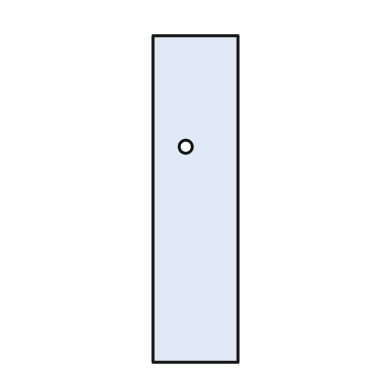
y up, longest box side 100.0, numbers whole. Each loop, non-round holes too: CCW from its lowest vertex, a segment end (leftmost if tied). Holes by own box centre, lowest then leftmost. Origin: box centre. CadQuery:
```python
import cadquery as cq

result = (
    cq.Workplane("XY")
    .moveTo(-13.0, -50.0)
    .lineTo(13.0, -50.0)
    .lineTo(13.0, 50.0)
    .lineTo(-13.0, 50.0)
    .close()
    .moveTo(-3.0, 16.0)
    .circle(2.0)
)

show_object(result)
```